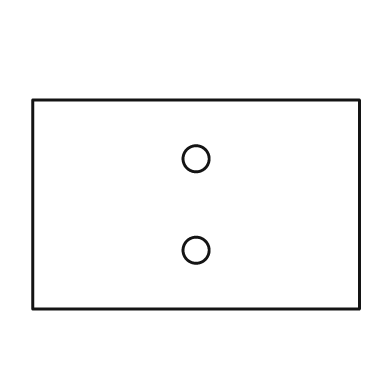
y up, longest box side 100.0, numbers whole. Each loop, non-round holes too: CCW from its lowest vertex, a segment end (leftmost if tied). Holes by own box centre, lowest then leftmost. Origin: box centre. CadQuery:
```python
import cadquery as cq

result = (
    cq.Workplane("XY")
    .moveTo(-50.0, -32.0)
    .lineTo(50.0, -32.0)
    .lineTo(50.0, 32.0)
    .lineTo(-50.0, 32.0)
    .close()
    .moveTo(0.0, -14.0)
    .circle(4.0)
    .moveTo(0.0, 14.0)
    .circle(4.0)
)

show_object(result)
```